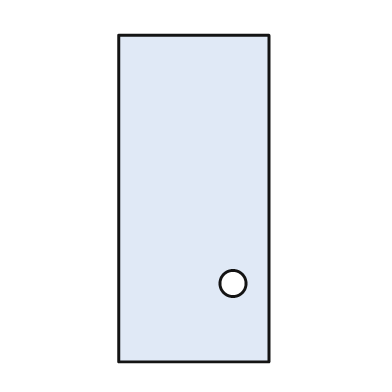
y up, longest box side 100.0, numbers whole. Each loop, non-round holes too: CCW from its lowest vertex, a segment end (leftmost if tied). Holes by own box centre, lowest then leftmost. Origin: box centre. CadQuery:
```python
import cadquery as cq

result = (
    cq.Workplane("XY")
    .moveTo(-23.0, -50.0)
    .lineTo(23.0, -50.0)
    .lineTo(23.0, 50.0)
    .lineTo(-23.0, 50.0)
    .close()
    .moveTo(12.0, -26.0)
    .circle(4.0)
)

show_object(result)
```